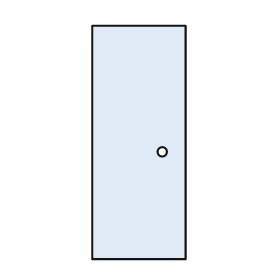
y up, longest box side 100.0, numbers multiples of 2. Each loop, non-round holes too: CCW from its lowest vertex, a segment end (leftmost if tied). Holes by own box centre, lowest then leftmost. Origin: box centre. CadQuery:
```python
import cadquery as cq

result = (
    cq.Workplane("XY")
    .moveTo(-20.0, -50.0)
    .lineTo(20.0, -50.0)
    .lineTo(20.0, 50.0)
    .lineTo(-20.0, 50.0)
    .close()
    .moveTo(10.0, -4.0)
    .circle(2.0)
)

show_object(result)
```